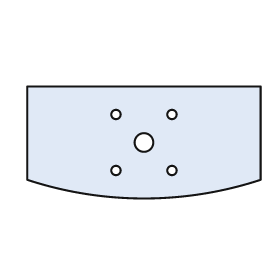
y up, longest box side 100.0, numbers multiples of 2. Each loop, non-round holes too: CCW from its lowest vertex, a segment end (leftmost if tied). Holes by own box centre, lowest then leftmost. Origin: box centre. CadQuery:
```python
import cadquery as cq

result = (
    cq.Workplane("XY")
    .moveTo(-50.0, -16.0)
    .threePointArc((0.0, -24.0), (50.0, -16.0))
    .lineTo(50.0, 24.0)
    .lineTo(-50.0, 24.0)
    .close()
    .moveTo(-12.0, -12.0)
    .circle(2.0)
    .moveTo(12.0, -12.0)
    .circle(2.0)
    .moveTo(0.0, 0.0)
    .circle(4.0)
    .moveTo(-12.0, 12.0)
    .circle(2.0)
    .moveTo(12.0, 12.0)
    .circle(2.0)
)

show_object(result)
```